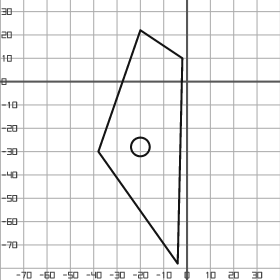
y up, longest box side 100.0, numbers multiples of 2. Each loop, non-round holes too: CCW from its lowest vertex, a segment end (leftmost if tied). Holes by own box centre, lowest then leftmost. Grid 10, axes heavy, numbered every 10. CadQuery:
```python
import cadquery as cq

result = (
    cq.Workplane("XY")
    .moveTo(-4.0, -78.0)
    .lineTo(-2.0, 10.0)
    .lineTo(-20.0, 22.0)
    .lineTo(-38.0, -30.0)
    .close()
    .moveTo(-20.0, -28.0)
    .circle(4.0)
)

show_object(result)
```